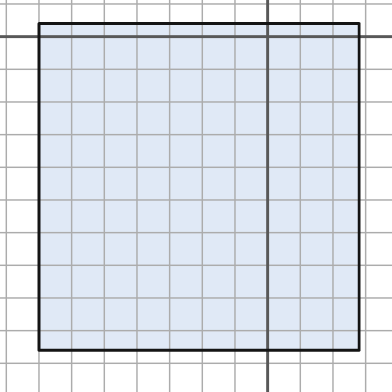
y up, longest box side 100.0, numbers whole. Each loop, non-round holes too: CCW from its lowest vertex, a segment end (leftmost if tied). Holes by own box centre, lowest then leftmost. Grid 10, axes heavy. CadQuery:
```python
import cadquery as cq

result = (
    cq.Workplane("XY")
    .moveTo(-70.0, -96.0)
    .lineTo(28.0, -96.0)
    .lineTo(28.0, 4.0)
    .lineTo(-70.0, 4.0)
    .close()
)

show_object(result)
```